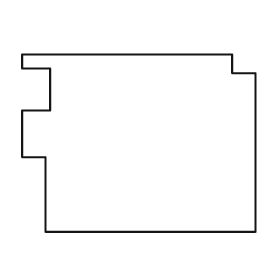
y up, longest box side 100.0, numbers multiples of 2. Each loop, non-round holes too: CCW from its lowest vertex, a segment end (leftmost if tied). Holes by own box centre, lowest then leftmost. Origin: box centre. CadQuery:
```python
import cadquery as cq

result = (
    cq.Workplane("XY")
    .moveTo(-40.0, -38.0)
    .lineTo(50.0, -38.0)
    .lineTo(50.0, 30.0)
    .lineTo(40.0, 30.0)
    .lineTo(40.0, 38.0)
    .lineTo(-50.0, 38.0)
    .lineTo(-50.0, 32.0)
    .lineTo(-38.0, 32.0)
    .lineTo(-38.0, 14.0)
    .lineTo(-50.0, 14.0)
    .lineTo(-50.0, -6.0)
    .lineTo(-40.0, -6.0)
    .close()
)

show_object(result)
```